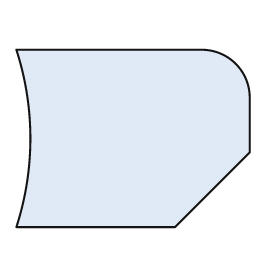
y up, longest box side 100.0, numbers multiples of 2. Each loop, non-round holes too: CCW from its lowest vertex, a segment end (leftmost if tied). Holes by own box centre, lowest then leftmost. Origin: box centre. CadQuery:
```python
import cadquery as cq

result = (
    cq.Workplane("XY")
    .moveTo(-50.0, -38.0)
    .lineTo(18.0, -38.0)
    .lineTo(50.0, -6.0)
    .lineTo(50.0, 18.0)
    .threePointArc((44.0, 32.0), (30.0, 38.0))
    .lineTo(-50.0, 38.0)
    .threePointArc((-44.0, 0.0), (-50.0, -38.0))
    .close()
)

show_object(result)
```